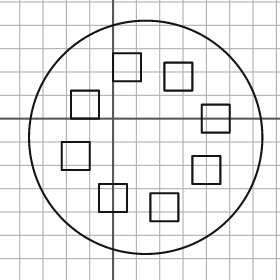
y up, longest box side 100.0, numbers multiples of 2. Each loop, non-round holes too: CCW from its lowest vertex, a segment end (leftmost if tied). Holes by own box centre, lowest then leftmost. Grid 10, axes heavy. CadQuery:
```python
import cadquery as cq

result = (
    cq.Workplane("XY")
    .moveTo(14.0, -8.0)
    .circle(50.0)
    .moveTo(16.0, -44.0)
    .lineTo(28.0, -44.0)
    .lineTo(28.0, -32.0)
    .lineTo(16.0, -32.0)
    .close()
    .moveTo(-6.0, -40.0)
    .lineTo(6.0, -40.0)
    .lineTo(6.0, -28.0)
    .lineTo(-6.0, -28.0)
    .close()
    .moveTo(34.0, -28.0)
    .lineTo(46.0, -28.0)
    .lineTo(46.0, -16.0)
    .lineTo(34.0, -16.0)
    .close()
    .moveTo(-22.0, -22.0)
    .lineTo(-10.0, -22.0)
    .lineTo(-10.0, -10.0)
    .lineTo(-22.0, -10.0)
    .close()
    .moveTo(38.0, -6.0)
    .lineTo(50.0, -6.0)
    .lineTo(50.0, 6.0)
    .lineTo(38.0, 6.0)
    .close()
    .moveTo(-18.0, 0.0)
    .lineTo(-6.0, 0.0)
    .lineTo(-6.0, 12.0)
    .lineTo(-18.0, 12.0)
    .close()
    .moveTo(22.0, 12.0)
    .lineTo(34.0, 12.0)
    .lineTo(34.0, 24.0)
    .lineTo(22.0, 24.0)
    .close()
    .moveTo(0.0, 16.0)
    .lineTo(12.0, 16.0)
    .lineTo(12.0, 28.0)
    .lineTo(0.0, 28.0)
    .close()
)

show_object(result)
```